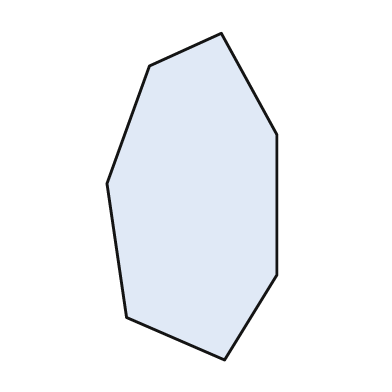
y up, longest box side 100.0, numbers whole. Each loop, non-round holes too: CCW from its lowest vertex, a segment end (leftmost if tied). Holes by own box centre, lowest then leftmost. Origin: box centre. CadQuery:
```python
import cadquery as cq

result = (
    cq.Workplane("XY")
    .moveTo(10.0, -50.0)
    .lineTo(26.0, -24.0)
    .lineTo(26.0, 19.0)
    .lineTo(9.0, 50.0)
    .lineTo(-13.0, 40.0)
    .lineTo(-26.0, 4.0)
    .lineTo(-20.0, -37.0)
    .close()
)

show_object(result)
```